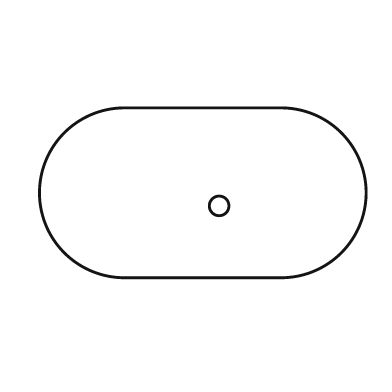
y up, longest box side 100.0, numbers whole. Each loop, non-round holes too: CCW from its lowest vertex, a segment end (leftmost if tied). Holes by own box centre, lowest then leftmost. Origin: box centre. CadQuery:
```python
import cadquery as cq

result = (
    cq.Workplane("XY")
    .moveTo(-24.0, -26.0)
    .lineTo(24.0, -26.0)
    .threePointArc((50.0, 0.0), (24.0, 26.0))
    .lineTo(-24.0, 26.0)
    .threePointArc((-50.0, 0.0), (-24.0, -26.0))
    .close()
    .moveTo(5.0, -4.0)
    .circle(3.0)
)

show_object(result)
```